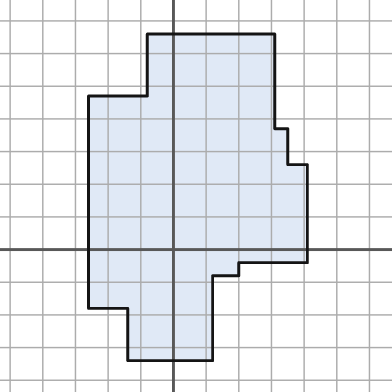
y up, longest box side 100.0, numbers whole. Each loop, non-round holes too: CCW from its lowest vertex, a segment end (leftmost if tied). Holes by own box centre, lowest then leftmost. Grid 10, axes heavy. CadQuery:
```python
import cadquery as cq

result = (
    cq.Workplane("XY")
    .moveTo(-14.0, -34.0)
    .lineTo(12.0, -34.0)
    .lineTo(12.0, -8.0)
    .lineTo(20.0, -8.0)
    .lineTo(20.0, -4.0)
    .lineTo(41.0, -4.0)
    .lineTo(41.0, 26.0)
    .lineTo(35.0, 26.0)
    .lineTo(35.0, 37.0)
    .lineTo(31.0, 37.0)
    .lineTo(31.0, 66.0)
    .lineTo(-8.0, 66.0)
    .lineTo(-8.0, 47.0)
    .lineTo(-26.0, 47.0)
    .lineTo(-26.0, -18.0)
    .lineTo(-14.0, -18.0)
    .close()
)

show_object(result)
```